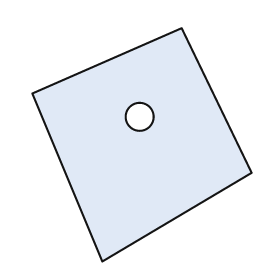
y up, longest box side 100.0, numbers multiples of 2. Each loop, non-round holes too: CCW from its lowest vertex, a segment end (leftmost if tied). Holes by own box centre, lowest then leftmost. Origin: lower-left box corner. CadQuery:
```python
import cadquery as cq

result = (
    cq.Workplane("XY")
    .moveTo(30.0, 0.0)
    .lineTo(94.0, 38.0)
    .lineTo(64.0, 100.0)
    .lineTo(0.0, 72.0)
    .close()
    .moveTo(46.0, 62.0)
    .circle(6.0)
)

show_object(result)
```